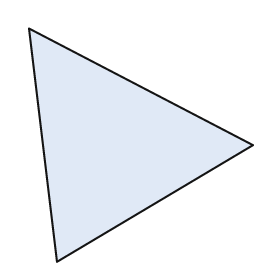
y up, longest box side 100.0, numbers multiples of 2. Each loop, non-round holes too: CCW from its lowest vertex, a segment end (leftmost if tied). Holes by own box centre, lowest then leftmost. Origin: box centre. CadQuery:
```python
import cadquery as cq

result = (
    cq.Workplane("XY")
    .moveTo(-36.0, -50.0)
    .lineTo(48.0, 0.0)
    .lineTo(-48.0, 50.0)
    .close()
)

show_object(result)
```